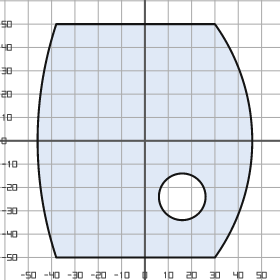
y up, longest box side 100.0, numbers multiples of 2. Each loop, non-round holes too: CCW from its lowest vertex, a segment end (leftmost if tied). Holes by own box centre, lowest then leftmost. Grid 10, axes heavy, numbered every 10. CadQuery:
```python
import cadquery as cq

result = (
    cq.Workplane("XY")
    .moveTo(-38.0, -50.0)
    .lineTo(30.0, -50.0)
    .threePointArc((46.0, 0.0), (30.0, 50.0))
    .lineTo(-38.0, 50.0)
    .threePointArc((-46.0, 0.0), (-38.0, -50.0))
    .close()
    .moveTo(16.0, -24.0)
    .circle(10.0)
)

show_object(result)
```